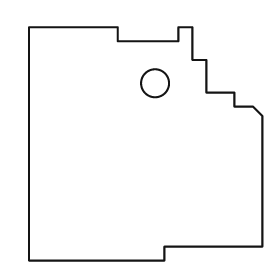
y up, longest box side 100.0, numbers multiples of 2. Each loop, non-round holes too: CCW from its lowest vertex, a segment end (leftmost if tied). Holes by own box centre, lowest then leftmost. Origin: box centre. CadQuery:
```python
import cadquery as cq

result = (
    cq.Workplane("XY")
    .moveTo(-50.0, -50.0)
    .lineTo(8.0, -50.0)
    .lineTo(8.0, -44.0)
    .lineTo(50.0, -44.0)
    .lineTo(50.0, 12.0)
    .lineTo(46.0, 16.0)
    .lineTo(38.0, 16.0)
    .lineTo(38.0, 22.0)
    .lineTo(26.0, 22.0)
    .lineTo(26.0, 36.0)
    .lineTo(20.0, 36.0)
    .lineTo(20.0, 50.0)
    .lineTo(14.0, 50.0)
    .lineTo(14.0, 44.0)
    .lineTo(-12.0, 44.0)
    .lineTo(-12.0, 50.0)
    .lineTo(-50.0, 50.0)
    .close()
    .moveTo(4.0, 26.0)
    .circle(6.0)
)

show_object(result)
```